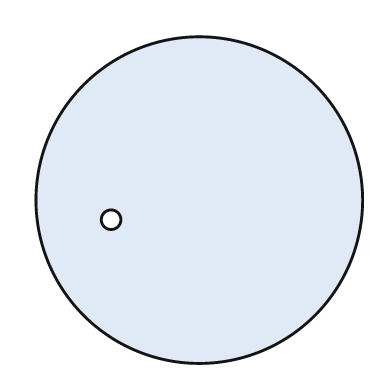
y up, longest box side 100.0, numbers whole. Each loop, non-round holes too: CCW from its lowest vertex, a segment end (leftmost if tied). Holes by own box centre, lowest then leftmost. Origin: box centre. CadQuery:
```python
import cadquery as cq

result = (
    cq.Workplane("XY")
    .moveTo(0.0, 0.0)
    .circle(50.0)
    .moveTo(-27.0, -6.0)
    .circle(3.0)
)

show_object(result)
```